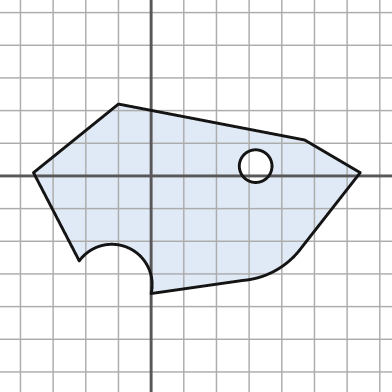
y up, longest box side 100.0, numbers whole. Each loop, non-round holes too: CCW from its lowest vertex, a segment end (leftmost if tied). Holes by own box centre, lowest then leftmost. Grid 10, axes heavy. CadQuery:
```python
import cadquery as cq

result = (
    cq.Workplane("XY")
    .moveTo(0.0, -36.0)
    .lineTo(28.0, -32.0)
    .threePointArc((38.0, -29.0), (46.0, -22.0))
    .lineTo(64.0, 1.0)
    .lineTo(47.0, 11.0)
    .lineTo(-10.0, 22.0)
    .lineTo(-36.0, 1.0)
    .lineTo(-22.0, -26.0)
    .threePointArc((-7.0, -22.0), (0.0, -36.0))
    .close()
    .moveTo(32.0, 3.0)
    .circle(5.0)
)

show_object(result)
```